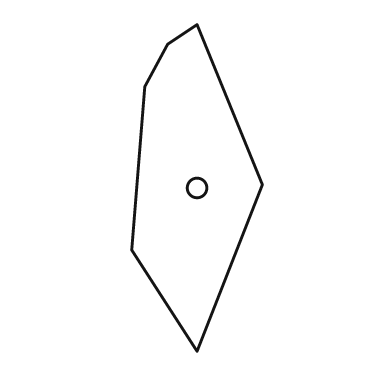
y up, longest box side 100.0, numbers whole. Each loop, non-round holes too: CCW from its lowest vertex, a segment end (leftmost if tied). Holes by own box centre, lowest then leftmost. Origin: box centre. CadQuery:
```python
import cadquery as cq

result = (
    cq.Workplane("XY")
    .moveTo(0.0, -50.0)
    .lineTo(20.0, 1.0)
    .lineTo(0.0, 50.0)
    .lineTo(-9.0, 44.0)
    .lineTo(-16.0, 31.0)
    .lineTo(-20.0, -19.0)
    .close()
    .moveTo(0.0, 0.0)
    .circle(3.0)
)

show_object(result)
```